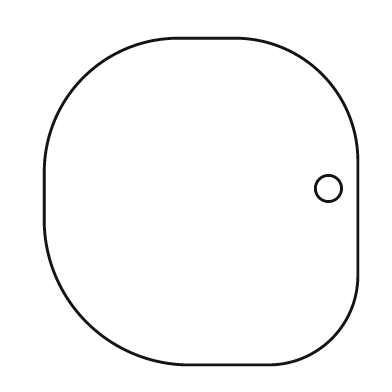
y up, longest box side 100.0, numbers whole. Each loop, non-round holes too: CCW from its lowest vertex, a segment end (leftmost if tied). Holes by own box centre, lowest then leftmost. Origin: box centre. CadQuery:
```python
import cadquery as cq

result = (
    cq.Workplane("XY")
    .moveTo(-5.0, -50.0)
    .lineTo(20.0, -50.0)
    .threePointArc((40.0, -42.0), (48.0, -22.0))
    .lineTo(48.0, 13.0)
    .threePointArc((37.0, 39.0), (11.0, 50.0))
    .lineTo(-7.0, 50.0)
    .threePointArc((-36.0, 38.0), (-48.0, 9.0))
    .lineTo(-48.0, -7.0)
    .threePointArc((-35.0, -37.0), (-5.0, -50.0))
    .close()
    .moveTo(39.0, 4.0)
    .circle(4.0)
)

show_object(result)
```